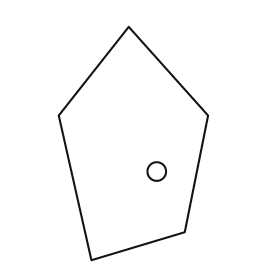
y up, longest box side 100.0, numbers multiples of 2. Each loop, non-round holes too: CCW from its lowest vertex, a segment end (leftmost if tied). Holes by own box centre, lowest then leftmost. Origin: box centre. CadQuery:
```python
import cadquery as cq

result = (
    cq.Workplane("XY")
    .moveTo(-18.0, -50.0)
    .lineTo(22.0, -38.0)
    .lineTo(32.0, 12.0)
    .lineTo(-2.0, 50.0)
    .lineTo(-32.0, 12.0)
    .close()
    .moveTo(10.0, -12.0)
    .circle(4.0)
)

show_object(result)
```